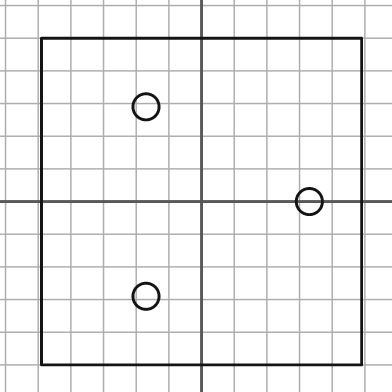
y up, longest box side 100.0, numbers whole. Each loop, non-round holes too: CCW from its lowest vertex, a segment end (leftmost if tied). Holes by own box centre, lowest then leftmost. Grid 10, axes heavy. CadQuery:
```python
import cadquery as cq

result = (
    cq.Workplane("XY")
    .moveTo(-49.0, -50.0)
    .lineTo(49.0, -50.0)
    .lineTo(49.0, 50.0)
    .lineTo(-49.0, 50.0)
    .close()
    .moveTo(-17.0, -29.0)
    .circle(4.0)
    .moveTo(33.0, 0.0)
    .circle(4.0)
    .moveTo(-17.0, 29.0)
    .circle(4.0)
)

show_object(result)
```